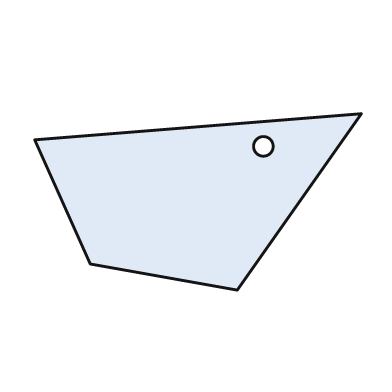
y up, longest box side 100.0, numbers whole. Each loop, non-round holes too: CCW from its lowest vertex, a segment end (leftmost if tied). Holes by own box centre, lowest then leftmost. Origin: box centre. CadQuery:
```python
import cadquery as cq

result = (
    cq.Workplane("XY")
    .moveTo(12.0, -27.0)
    .lineTo(50.0, 27.0)
    .lineTo(-50.0, 19.0)
    .lineTo(-33.0, -19.0)
    .close()
    .moveTo(20.0, 17.0)
    .circle(3.0)
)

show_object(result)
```